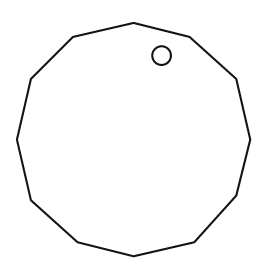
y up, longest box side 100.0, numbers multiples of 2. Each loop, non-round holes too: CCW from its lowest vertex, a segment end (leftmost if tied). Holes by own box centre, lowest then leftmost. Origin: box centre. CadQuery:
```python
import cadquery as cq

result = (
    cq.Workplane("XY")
    .moveTo(0.0, -50.0)
    .lineTo(26.0, -44.0)
    .lineTo(44.0, -24.0)
    .lineTo(50.0, 0.0)
    .lineTo(44.0, 26.0)
    .lineTo(24.0, 44.0)
    .lineTo(0.0, 50.0)
    .lineTo(-26.0, 44.0)
    .lineTo(-44.0, 26.0)
    .lineTo(-50.0, 0.0)
    .lineTo(-44.0, -26.0)
    .lineTo(-24.0, -44.0)
    .close()
    .moveTo(12.0, 36.0)
    .circle(4.0)
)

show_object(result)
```